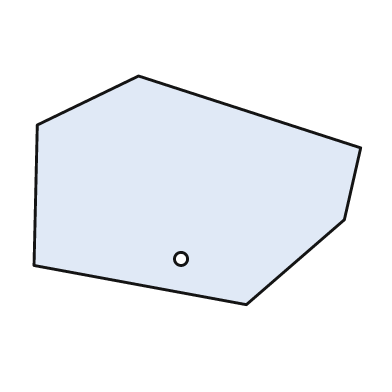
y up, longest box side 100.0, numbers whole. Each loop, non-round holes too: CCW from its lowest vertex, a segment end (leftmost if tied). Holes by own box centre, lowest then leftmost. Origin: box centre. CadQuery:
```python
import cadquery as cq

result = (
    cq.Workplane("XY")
    .moveTo(15.0, -35.0)
    .lineTo(45.0, -9.0)
    .lineTo(50.0, 13.0)
    .lineTo(-18.0, 35.0)
    .lineTo(-49.0, 20.0)
    .lineTo(-50.0, -23.0)
    .close()
    .moveTo(-5.0, -21.0)
    .circle(2.0)
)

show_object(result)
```